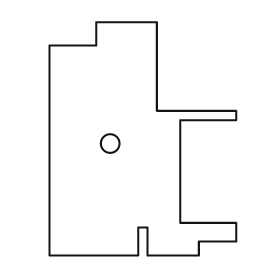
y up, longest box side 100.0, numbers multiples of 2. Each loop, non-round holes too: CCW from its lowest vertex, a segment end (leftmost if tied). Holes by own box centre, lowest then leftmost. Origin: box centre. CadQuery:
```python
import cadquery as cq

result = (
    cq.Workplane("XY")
    .moveTo(-40.0, -50.0)
    .lineTo(-2.0, -50.0)
    .lineTo(-2.0, -38.0)
    .lineTo(2.0, -38.0)
    .lineTo(2.0, -50.0)
    .lineTo(24.0, -50.0)
    .lineTo(24.0, -44.0)
    .lineTo(40.0, -44.0)
    .lineTo(40.0, -36.0)
    .lineTo(16.0, -36.0)
    .lineTo(16.0, 8.0)
    .lineTo(40.0, 8.0)
    .lineTo(40.0, 12.0)
    .lineTo(6.0, 12.0)
    .lineTo(6.0, 50.0)
    .lineTo(-20.0, 50.0)
    .lineTo(-20.0, 40.0)
    .lineTo(-40.0, 40.0)
    .close()
    .moveTo(-14.0, -2.0)
    .circle(4.0)
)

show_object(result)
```